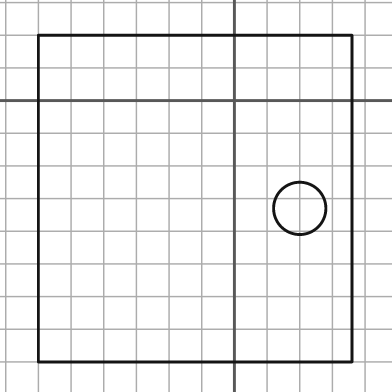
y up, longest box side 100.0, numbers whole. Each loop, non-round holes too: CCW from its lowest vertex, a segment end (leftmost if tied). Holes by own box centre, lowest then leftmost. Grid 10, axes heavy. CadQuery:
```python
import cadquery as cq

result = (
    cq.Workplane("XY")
    .moveTo(-60.0, -80.0)
    .lineTo(36.0, -80.0)
    .lineTo(36.0, 20.0)
    .lineTo(-60.0, 20.0)
    .close()
    .moveTo(20.0, -33.0)
    .circle(8.0)
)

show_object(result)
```